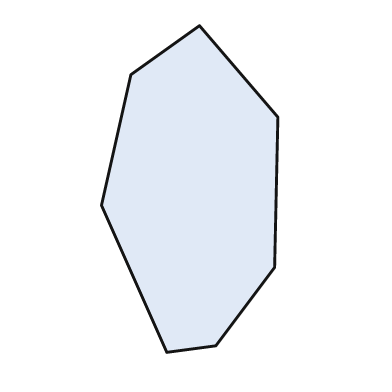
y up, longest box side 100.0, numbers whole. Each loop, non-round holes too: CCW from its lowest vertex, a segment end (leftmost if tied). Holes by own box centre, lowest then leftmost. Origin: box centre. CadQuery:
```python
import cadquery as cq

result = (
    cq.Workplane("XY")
    .moveTo(-7.0, -50.0)
    .lineTo(8.0, -48.0)
    .lineTo(26.0, -24.0)
    .lineTo(27.0, 22.0)
    .lineTo(3.0, 50.0)
    .lineTo(-18.0, 35.0)
    .lineTo(-27.0, -5.0)
    .close()
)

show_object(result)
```